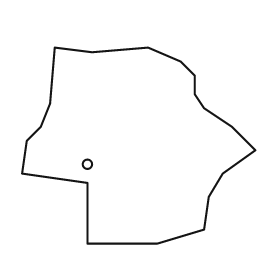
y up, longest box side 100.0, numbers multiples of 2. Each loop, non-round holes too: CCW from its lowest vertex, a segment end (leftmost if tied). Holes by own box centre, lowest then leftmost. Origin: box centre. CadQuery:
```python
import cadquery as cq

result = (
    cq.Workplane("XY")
    .moveTo(-22.0, -42.0)
    .lineTo(8.0, -42.0)
    .lineTo(28.0, -36.0)
    .lineTo(30.0, -22.0)
    .lineTo(36.0, -12.0)
    .lineTo(50.0, -2.0)
    .lineTo(40.0, 8.0)
    .lineTo(28.0, 16.0)
    .lineTo(24.0, 22.0)
    .lineTo(24.0, 30.0)
    .lineTo(18.0, 36.0)
    .lineTo(4.0, 42.0)
    .lineTo(-20.0, 40.0)
    .lineTo(-36.0, 42.0)
    .lineTo(-38.0, 18.0)
    .lineTo(-42.0, 8.0)
    .lineTo(-48.0, 2.0)
    .lineTo(-50.0, -12.0)
    .lineTo(-22.0, -16.0)
    .close()
    .moveTo(-22.0, -8.0)
    .circle(2.0)
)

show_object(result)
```